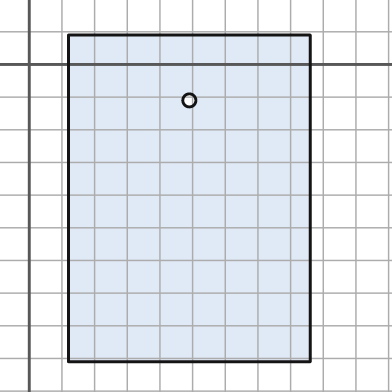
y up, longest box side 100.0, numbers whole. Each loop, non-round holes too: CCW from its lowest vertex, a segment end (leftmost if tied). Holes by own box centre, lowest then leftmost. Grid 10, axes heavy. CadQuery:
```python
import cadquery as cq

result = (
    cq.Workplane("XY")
    .moveTo(12.0, -91.0)
    .lineTo(86.0, -91.0)
    .lineTo(86.0, 9.0)
    .lineTo(12.0, 9.0)
    .close()
    .moveTo(49.0, -11.0)
    .circle(2.0)
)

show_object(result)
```